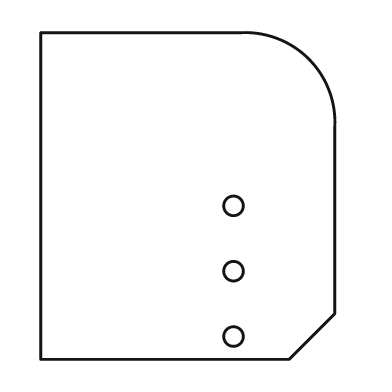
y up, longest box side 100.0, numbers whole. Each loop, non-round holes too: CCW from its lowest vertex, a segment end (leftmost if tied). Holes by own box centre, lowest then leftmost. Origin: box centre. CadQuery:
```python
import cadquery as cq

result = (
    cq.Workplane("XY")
    .moveTo(-45.0, -50.0)
    .lineTo(31.0, -50.0)
    .lineTo(45.0, -36.0)
    .lineTo(45.0, 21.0)
    .threePointArc((37.0, 42.0), (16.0, 50.0))
    .lineTo(-45.0, 50.0)
    .close()
    .moveTo(14.0, -43.0)
    .circle(3.0)
    .moveTo(14.0, -23.0)
    .circle(3.0)
    .moveTo(14.0, -3.0)
    .circle(3.0)
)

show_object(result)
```